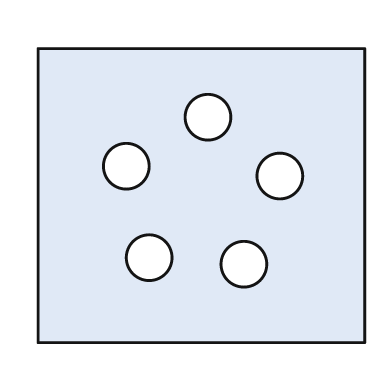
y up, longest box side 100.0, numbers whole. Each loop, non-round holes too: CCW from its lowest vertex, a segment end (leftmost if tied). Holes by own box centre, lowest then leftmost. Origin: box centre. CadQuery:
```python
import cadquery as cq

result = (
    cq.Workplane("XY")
    .moveTo(-50.0, -45.0)
    .lineTo(50.0, -45.0)
    .lineTo(50.0, 45.0)
    .lineTo(-50.0, 45.0)
    .close()
    .moveTo(13.0, -21.0)
    .circle(7.0)
    .moveTo(-16.0, -19.0)
    .circle(7.0)
    .moveTo(24.0, 6.0)
    .circle(7.0)
    .moveTo(-23.0, 9.0)
    .circle(7.0)
    .moveTo(2.0, 24.0)
    .circle(7.0)
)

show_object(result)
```